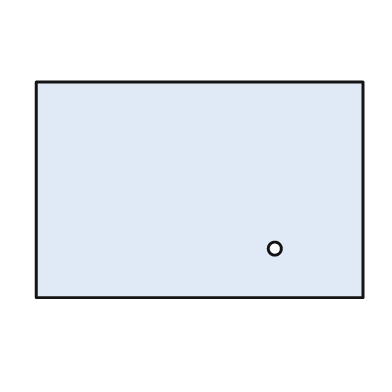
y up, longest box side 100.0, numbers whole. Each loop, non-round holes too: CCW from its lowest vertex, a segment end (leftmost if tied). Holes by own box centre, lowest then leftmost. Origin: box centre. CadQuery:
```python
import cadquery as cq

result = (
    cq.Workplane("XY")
    .moveTo(-50.0, -33.0)
    .lineTo(50.0, -33.0)
    .lineTo(50.0, 33.0)
    .lineTo(-50.0, 33.0)
    .close()
    .moveTo(23.0, -18.0)
    .circle(2.0)
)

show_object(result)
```